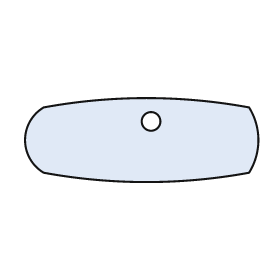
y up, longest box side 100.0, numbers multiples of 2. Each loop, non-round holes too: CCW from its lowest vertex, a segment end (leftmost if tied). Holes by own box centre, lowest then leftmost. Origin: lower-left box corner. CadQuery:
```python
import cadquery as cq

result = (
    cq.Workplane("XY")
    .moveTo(8.0, 4.0)
    .threePointArc((52.0, 0.0), (96.0, 4.0))
    .threePointArc((100.0, 18.0), (96.0, 32.0))
    .threePointArc((52.0, 36.0), (8.0, 32.0))
    .threePointArc((0.0, 18.0), (8.0, 4.0))
    .close()
    .moveTo(54.0, 26.0)
    .circle(4.0)
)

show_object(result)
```